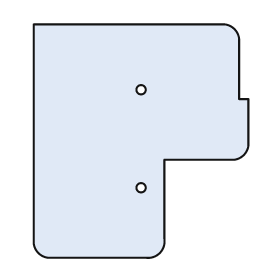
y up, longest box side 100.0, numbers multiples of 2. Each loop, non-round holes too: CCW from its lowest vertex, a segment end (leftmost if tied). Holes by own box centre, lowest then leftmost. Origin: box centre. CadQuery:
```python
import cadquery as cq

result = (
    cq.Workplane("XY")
    .moveTo(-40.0, -50.0)
    .lineTo(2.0, -50.0)
    .threePointArc((8.0, -48.0), (10.0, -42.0))
    .lineTo(10.0, -8.0)
    .lineTo(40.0, -8.0)
    .threePointArc((44.0, -6.0), (46.0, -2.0))
    .lineTo(46.0, 18.0)
    .lineTo(42.0, 18.0)
    .lineTo(42.0, 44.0)
    .threePointArc((40.0, 48.0), (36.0, 50.0))
    .lineTo(-46.0, 50.0)
    .lineTo(-46.0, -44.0)
    .threePointArc((-44.0, -48.0), (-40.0, -50.0))
    .close()
    .moveTo(0.0, -20.0)
    .circle(2.0)
    .moveTo(0.0, 22.0)
    .circle(2.0)
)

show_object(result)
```